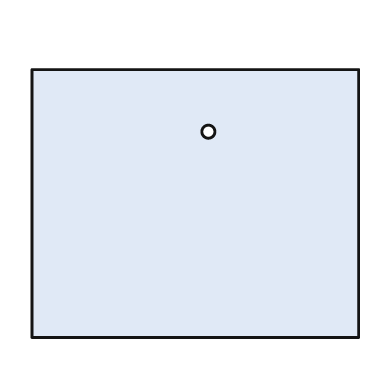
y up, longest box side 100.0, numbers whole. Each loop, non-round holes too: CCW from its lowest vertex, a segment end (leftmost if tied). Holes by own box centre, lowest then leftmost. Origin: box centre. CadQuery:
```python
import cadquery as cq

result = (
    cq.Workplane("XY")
    .moveTo(-50.0, -41.0)
    .lineTo(50.0, -41.0)
    .lineTo(50.0, 41.0)
    .lineTo(-50.0, 41.0)
    .close()
    .moveTo(4.0, 22.0)
    .circle(2.0)
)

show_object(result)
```